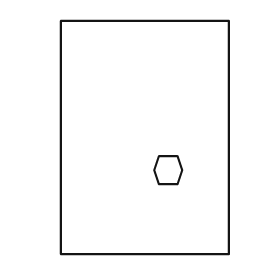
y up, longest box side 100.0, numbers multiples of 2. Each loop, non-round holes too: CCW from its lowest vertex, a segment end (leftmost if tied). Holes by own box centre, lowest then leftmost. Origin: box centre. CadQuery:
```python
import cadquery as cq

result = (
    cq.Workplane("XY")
    .moveTo(-36.0, -50.0)
    .lineTo(36.0, -50.0)
    .lineTo(36.0, 50.0)
    .lineTo(-36.0, 50.0)
    .close()
    .moveTo(6.0, -20.0)
    .lineTo(14.0, -20.0)
    .lineTo(16.0, -14.0)
    .lineTo(14.0, -8.0)
    .lineTo(6.0, -8.0)
    .lineTo(4.0, -14.0)
    .close()
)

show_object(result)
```